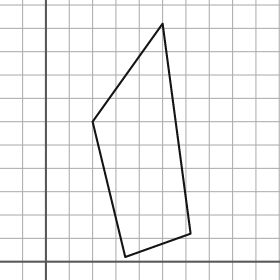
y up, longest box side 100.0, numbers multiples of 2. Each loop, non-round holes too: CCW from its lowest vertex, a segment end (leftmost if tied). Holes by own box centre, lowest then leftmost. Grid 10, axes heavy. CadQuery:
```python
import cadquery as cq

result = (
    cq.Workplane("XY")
    .moveTo(34.0, 2.0)
    .lineTo(62.0, 12.0)
    .lineTo(50.0, 102.0)
    .lineTo(20.0, 60.0)
    .close()
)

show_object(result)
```